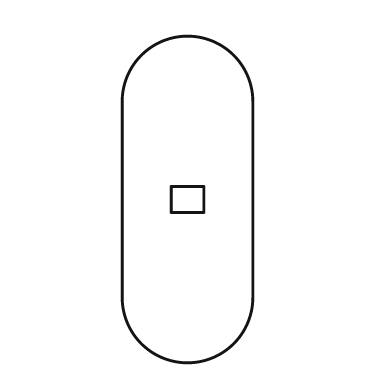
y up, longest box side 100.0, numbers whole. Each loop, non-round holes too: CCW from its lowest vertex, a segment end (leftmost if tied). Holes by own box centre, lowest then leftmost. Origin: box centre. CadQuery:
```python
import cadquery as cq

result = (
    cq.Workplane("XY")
    .moveTo(-20.0, -30.0)
    .threePointArc((0.0, -50.0), (20.0, -30.0))
    .lineTo(20.0, 30.0)
    .threePointArc((0.0, 50.0), (-20.0, 30.0))
    .close()
    .moveTo(-5.0, -4.0)
    .lineTo(5.0, -4.0)
    .lineTo(5.0, 4.0)
    .lineTo(-5.0, 4.0)
    .close()
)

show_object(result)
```